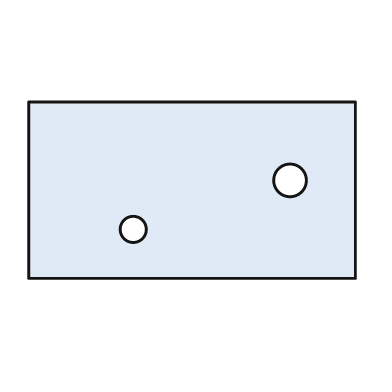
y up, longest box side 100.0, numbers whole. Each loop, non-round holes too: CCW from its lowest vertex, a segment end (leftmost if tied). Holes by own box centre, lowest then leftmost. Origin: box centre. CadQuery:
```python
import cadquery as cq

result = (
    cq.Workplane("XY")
    .moveTo(-50.0, -27.0)
    .lineTo(50.0, -27.0)
    .lineTo(50.0, 27.0)
    .lineTo(-50.0, 27.0)
    .close()
    .moveTo(-18.0, -12.0)
    .circle(4.0)
    .moveTo(30.0, 3.0)
    .circle(5.0)
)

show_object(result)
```